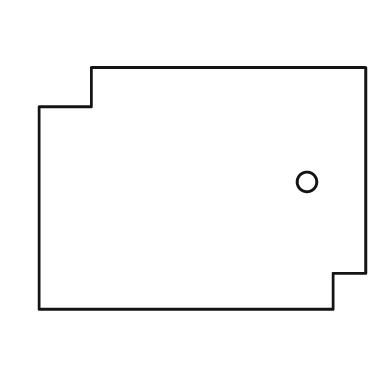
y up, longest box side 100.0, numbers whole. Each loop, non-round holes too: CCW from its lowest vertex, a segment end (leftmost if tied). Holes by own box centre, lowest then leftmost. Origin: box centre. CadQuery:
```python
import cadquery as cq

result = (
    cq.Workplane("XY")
    .moveTo(-50.0, -37.0)
    .lineTo(40.0, -37.0)
    .lineTo(40.0, -26.0)
    .lineTo(50.0, -26.0)
    .lineTo(50.0, 37.0)
    .lineTo(-34.0, 37.0)
    .lineTo(-34.0, 25.0)
    .lineTo(-50.0, 25.0)
    .close()
    .moveTo(32.0, 2.0)
    .circle(3.0)
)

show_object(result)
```